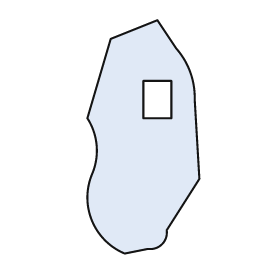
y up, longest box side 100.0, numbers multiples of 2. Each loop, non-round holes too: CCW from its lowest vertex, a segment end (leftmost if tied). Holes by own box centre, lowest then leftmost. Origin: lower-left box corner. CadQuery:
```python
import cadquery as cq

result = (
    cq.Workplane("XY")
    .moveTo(16.0, 0.0)
    .lineTo(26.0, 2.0)
    .threePointArc((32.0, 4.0), (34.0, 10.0))
    .lineTo(48.0, 32.0)
    .lineTo(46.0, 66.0)
    .threePointArc((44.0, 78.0), (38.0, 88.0))
    .lineTo(30.0, 100.0)
    .lineTo(10.0, 92.0)
    .lineTo(0.0, 58.0)
    .threePointArc((4.0, 46.0), (2.0, 34.0))
    .threePointArc((2.0, 14.0), (16.0, 0.0))
    .close()
    .moveTo(24.0, 58.0)
    .lineTo(36.0, 58.0)
    .lineTo(36.0, 74.0)
    .lineTo(24.0, 74.0)
    .close()
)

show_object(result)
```